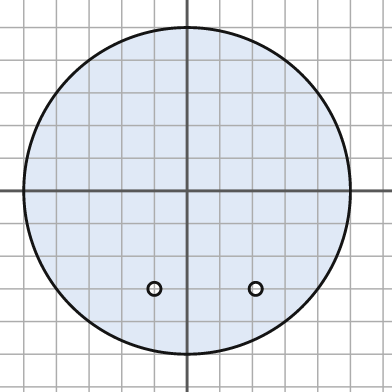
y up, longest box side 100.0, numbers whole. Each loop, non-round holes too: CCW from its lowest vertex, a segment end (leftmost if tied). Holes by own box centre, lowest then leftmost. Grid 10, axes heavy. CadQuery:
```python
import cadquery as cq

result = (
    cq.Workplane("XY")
    .moveTo(0.0, 0.0)
    .circle(50.0)
    .moveTo(-10.0, -30.0)
    .circle(2.0)
    .moveTo(21.0, -30.0)
    .circle(2.0)
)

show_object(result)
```